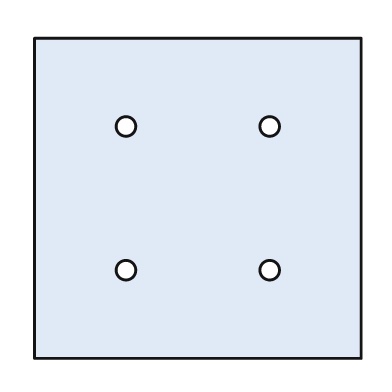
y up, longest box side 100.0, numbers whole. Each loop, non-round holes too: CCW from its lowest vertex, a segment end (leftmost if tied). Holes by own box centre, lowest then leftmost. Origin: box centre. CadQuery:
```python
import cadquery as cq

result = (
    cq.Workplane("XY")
    .moveTo(-50.0, -49.0)
    .lineTo(50.0, -49.0)
    .lineTo(50.0, 49.0)
    .lineTo(-50.0, 49.0)
    .close()
    .moveTo(-22.0, -22.0)
    .circle(3.0)
    .moveTo(22.0, -22.0)
    .circle(3.0)
    .moveTo(-22.0, 22.0)
    .circle(3.0)
    .moveTo(22.0, 22.0)
    .circle(3.0)
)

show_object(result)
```